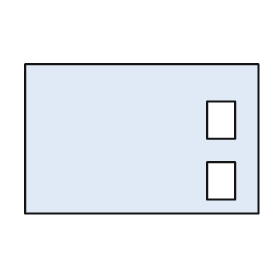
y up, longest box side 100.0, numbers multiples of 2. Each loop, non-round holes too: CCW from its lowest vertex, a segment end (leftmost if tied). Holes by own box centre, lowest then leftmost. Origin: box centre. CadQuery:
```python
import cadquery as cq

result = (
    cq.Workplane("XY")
    .moveTo(-50.0, -32.0)
    .lineTo(50.0, -32.0)
    .lineTo(50.0, 32.0)
    .lineTo(-50.0, 32.0)
    .close()
    .moveTo(28.0, -26.0)
    .lineTo(40.0, -26.0)
    .lineTo(40.0, -10.0)
    .lineTo(28.0, -10.0)
    .close()
    .moveTo(28.0, 0.0)
    .lineTo(40.0, 0.0)
    .lineTo(40.0, 16.0)
    .lineTo(28.0, 16.0)
    .close()
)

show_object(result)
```